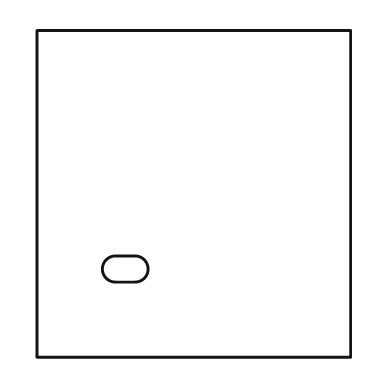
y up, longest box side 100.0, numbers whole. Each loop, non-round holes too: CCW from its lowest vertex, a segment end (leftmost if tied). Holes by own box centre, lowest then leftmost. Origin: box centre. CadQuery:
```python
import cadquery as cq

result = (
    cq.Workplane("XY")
    .moveTo(-48.0, -50.0)
    .lineTo(48.0, -50.0)
    .lineTo(48.0, 50.0)
    .lineTo(-48.0, 50.0)
    .close()
    .moveTo(-24.0, -27.0)
    .lineTo(-18.0, -27.0)
    .threePointArc((-14.0, -23.0), (-18.0, -19.0))
    .lineTo(-24.0, -19.0)
    .threePointArc((-28.0, -23.0), (-24.0, -27.0))
    .close()
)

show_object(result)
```